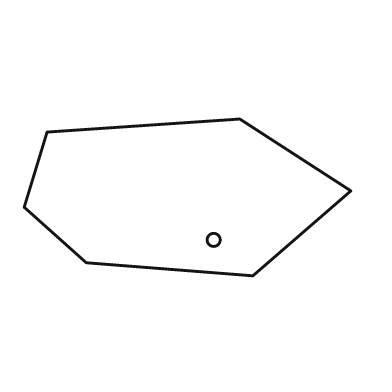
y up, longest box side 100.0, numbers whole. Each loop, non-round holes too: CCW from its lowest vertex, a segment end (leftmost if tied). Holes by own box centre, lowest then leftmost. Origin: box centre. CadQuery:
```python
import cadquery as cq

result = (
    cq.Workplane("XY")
    .moveTo(20.0, -24.0)
    .lineTo(50.0, 2.0)
    .lineTo(16.0, 24.0)
    .lineTo(-43.0, 20.0)
    .lineTo(-50.0, -3.0)
    .lineTo(-31.0, -20.0)
    .close()
    .moveTo(8.0, -13.0)
    .circle(2.0)
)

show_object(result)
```